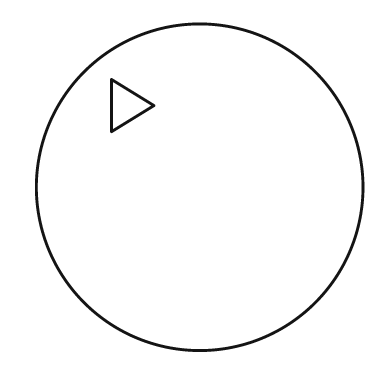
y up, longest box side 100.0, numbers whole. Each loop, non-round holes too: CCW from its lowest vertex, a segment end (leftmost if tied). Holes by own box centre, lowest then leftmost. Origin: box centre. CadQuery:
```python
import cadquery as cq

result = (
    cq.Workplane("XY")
    .moveTo(0.0, 0.0)
    .circle(50.0)
    .moveTo(-27.0, 17.0)
    .lineTo(-14.0, 25.0)
    .lineTo(-27.0, 33.0)
    .close()
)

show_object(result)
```